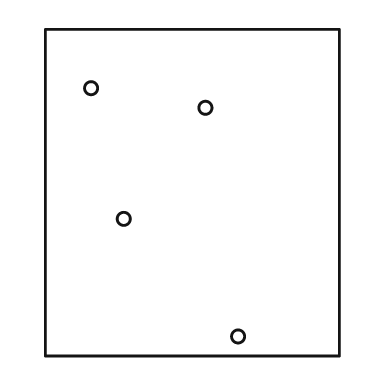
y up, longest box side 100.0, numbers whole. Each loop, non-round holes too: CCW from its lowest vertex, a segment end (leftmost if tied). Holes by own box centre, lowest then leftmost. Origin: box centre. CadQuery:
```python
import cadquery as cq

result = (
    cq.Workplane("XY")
    .moveTo(-45.0, -50.0)
    .lineTo(45.0, -50.0)
    .lineTo(45.0, 50.0)
    .lineTo(-45.0, 50.0)
    .close()
    .moveTo(14.0, -44.0)
    .circle(2.0)
    .moveTo(-21.0, -8.0)
    .circle(2.0)
    .moveTo(4.0, 26.0)
    .circle(2.0)
    .moveTo(-31.0, 32.0)
    .circle(2.0)
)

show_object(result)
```